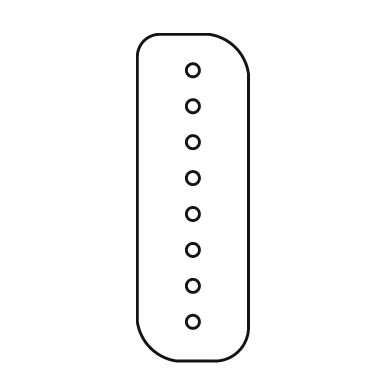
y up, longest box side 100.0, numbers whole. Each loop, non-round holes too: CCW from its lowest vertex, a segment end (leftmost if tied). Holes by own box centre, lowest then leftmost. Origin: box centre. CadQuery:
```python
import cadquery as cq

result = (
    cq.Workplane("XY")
    .moveTo(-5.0, -50.0)
    .lineTo(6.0, -50.0)
    .threePointArc((14.0, -47.0), (17.0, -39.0))
    .lineTo(17.0, 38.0)
    .threePointArc((13.0, 46.0), (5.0, 50.0))
    .lineTo(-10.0, 50.0)
    .threePointArc((-15.0, 48.0), (-17.0, 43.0))
    .lineTo(-17.0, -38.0)
    .threePointArc((-13.0, -46.0), (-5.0, -50.0))
    .close()
    .moveTo(0.0, -38.0)
    .circle(2.0)
    .moveTo(0.0, -27.0)
    .circle(2.0)
    .moveTo(0.0, -16.0)
    .circle(2.0)
    .moveTo(0.0, -5.0)
    .circle(2.0)
    .moveTo(0.0, 6.0)
    .circle(2.0)
    .moveTo(0.0, 17.0)
    .circle(2.0)
    .moveTo(0.0, 28.0)
    .circle(2.0)
    .moveTo(0.0, 39.0)
    .circle(2.0)
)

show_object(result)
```